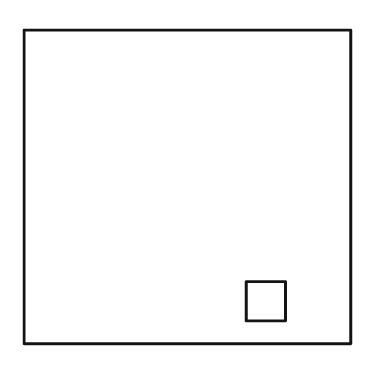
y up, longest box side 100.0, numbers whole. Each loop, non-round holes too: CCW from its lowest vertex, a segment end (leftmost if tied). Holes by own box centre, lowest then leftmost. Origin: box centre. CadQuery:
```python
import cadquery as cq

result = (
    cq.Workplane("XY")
    .moveTo(-50.0, -48.0)
    .lineTo(50.0, -48.0)
    .lineTo(50.0, 48.0)
    .lineTo(-50.0, 48.0)
    .close()
    .moveTo(18.0, -41.0)
    .lineTo(30.0, -41.0)
    .lineTo(30.0, -29.0)
    .lineTo(18.0, -29.0)
    .close()
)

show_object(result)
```